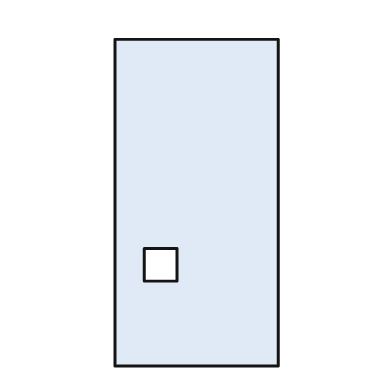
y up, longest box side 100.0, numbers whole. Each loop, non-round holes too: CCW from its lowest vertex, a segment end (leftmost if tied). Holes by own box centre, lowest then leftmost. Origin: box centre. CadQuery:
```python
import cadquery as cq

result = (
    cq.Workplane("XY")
    .moveTo(-25.0, -50.0)
    .lineTo(25.0, -50.0)
    .lineTo(25.0, 50.0)
    .lineTo(-25.0, 50.0)
    .close()
    .moveTo(-16.0, -24.0)
    .lineTo(-6.0, -24.0)
    .lineTo(-6.0, -14.0)
    .lineTo(-16.0, -14.0)
    .close()
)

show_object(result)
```